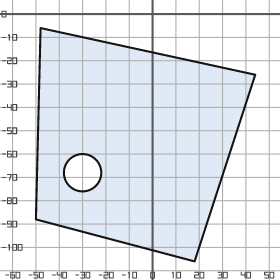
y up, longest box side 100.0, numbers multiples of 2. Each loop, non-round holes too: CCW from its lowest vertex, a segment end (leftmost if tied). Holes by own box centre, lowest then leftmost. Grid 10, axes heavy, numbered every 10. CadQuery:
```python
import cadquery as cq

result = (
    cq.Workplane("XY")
    .moveTo(18.0, -106.0)
    .lineTo(44.0, -26.0)
    .lineTo(-48.0, -6.0)
    .lineTo(-50.0, -88.0)
    .close()
    .moveTo(-30.0, -68.0)
    .circle(8.0)
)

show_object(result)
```